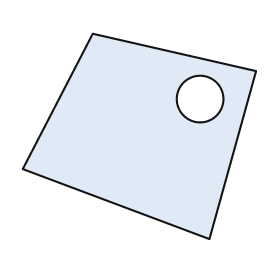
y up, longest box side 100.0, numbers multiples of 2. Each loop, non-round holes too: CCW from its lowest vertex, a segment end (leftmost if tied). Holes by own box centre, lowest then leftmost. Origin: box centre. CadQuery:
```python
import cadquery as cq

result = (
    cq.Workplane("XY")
    .moveTo(30.0, -44.0)
    .lineTo(50.0, 28.0)
    .lineTo(-20.0, 44.0)
    .lineTo(-50.0, -14.0)
    .close()
    .moveTo(26.0, 16.0)
    .circle(10.0)
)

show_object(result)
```